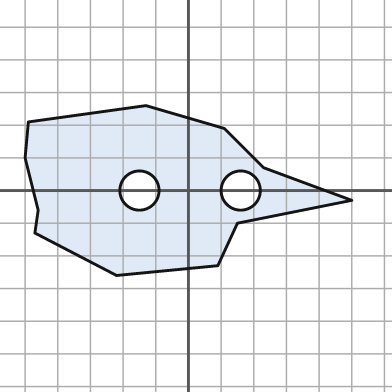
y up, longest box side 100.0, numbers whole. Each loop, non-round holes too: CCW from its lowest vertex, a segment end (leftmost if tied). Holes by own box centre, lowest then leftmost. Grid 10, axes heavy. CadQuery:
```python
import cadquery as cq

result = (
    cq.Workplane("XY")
    .moveTo(-22.0, -26.0)
    .lineTo(9.0, -23.0)
    .lineTo(15.0, -10.0)
    .lineTo(50.0, -3.0)
    .lineTo(23.0, 7.0)
    .lineTo(11.0, 19.0)
    .lineTo(-13.0, 26.0)
    .lineTo(-49.0, 21.0)
    .lineTo(-50.0, 10.0)
    .lineTo(-46.0, -6.0)
    .lineTo(-47.0, -13.0)
    .close()
    .moveTo(-15.0, 0.0)
    .circle(6.0)
    .moveTo(16.0, 0.0)
    .circle(6.0)
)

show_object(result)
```